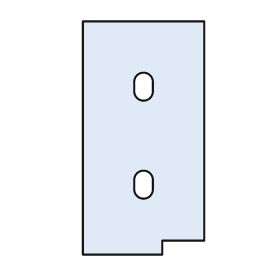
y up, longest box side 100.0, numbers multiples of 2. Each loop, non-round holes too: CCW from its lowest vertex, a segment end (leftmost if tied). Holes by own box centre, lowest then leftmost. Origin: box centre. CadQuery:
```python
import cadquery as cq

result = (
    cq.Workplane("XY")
    .moveTo(-26.0, -50.0)
    .lineTo(8.0, -50.0)
    .lineTo(8.0, -44.0)
    .lineTo(26.0, -44.0)
    .lineTo(26.0, 50.0)
    .lineTo(-26.0, 50.0)
    .close()
    .moveTo(-4.0, -22.0)
    .threePointArc((0.0, -26.0), (4.0, -22.0))
    .lineTo(4.0, -18.0)
    .threePointArc((0.0, -14.0), (-4.0, -18.0))
    .close()
    .moveTo(-4.0, 20.0)
    .threePointArc((0.0, 16.0), (4.0, 20.0))
    .lineTo(4.0, 24.0)
    .threePointArc((0.0, 28.0), (-4.0, 24.0))
    .close()
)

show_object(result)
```